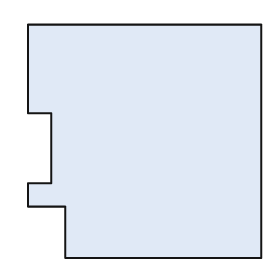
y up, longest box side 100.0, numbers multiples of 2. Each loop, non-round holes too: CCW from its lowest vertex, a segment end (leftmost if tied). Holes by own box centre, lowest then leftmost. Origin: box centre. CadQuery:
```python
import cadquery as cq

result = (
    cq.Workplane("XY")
    .moveTo(-34.0, -50.0)
    .lineTo(50.0, -50.0)
    .lineTo(50.0, 50.0)
    .lineTo(-50.0, 50.0)
    .lineTo(-50.0, 12.0)
    .lineTo(-40.0, 12.0)
    .lineTo(-40.0, -18.0)
    .lineTo(-50.0, -18.0)
    .lineTo(-50.0, -28.0)
    .lineTo(-34.0, -28.0)
    .close()
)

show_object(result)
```